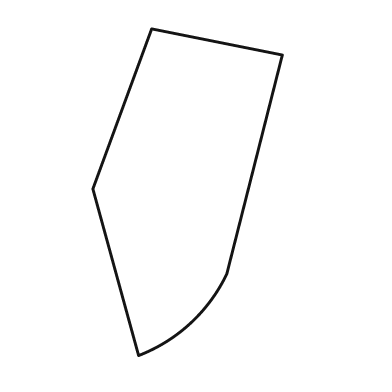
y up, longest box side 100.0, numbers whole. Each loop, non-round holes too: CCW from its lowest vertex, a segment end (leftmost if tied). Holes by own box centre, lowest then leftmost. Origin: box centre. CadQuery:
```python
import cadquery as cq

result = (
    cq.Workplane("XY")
    .moveTo(-15.0, -50.0)
    .threePointArc((1.0, -40.0), (12.0, -25.0))
    .lineTo(29.0, 42.0)
    .lineTo(-11.0, 50.0)
    .lineTo(-29.0, 1.0)
    .close()
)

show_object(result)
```